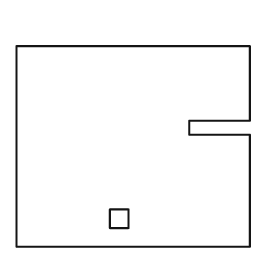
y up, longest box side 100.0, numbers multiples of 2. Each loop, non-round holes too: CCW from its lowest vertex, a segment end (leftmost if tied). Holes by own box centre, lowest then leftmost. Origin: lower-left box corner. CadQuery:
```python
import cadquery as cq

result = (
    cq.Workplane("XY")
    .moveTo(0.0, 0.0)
    .lineTo(100.0, 0.0)
    .lineTo(100.0, 48.0)
    .lineTo(74.0, 48.0)
    .lineTo(74.0, 54.0)
    .lineTo(100.0, 54.0)
    .lineTo(100.0, 86.0)
    .lineTo(0.0, 86.0)
    .close()
    .moveTo(40.0, 8.0)
    .lineTo(48.0, 8.0)
    .lineTo(48.0, 16.0)
    .lineTo(40.0, 16.0)
    .close()
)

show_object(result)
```